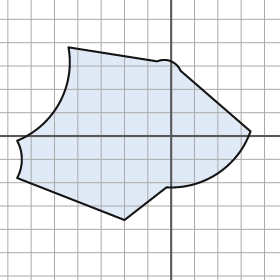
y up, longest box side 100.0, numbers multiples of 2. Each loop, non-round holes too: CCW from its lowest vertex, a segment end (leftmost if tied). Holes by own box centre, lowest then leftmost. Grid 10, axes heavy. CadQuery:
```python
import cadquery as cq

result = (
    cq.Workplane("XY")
    .moveTo(-20.0, -36.0)
    .lineTo(-2.0, -22.0)
    .threePointArc((20.0, -16.0), (34.0, 2.0))
    .lineTo(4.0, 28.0)
    .threePointArc((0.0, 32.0), (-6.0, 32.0))
    .lineTo(-44.0, 38.0)
    .threePointArc((-48.0, 14.0), (-66.0, -2.0))
    .threePointArc((-64.0, -10.0), (-66.0, -18.0))
    .close()
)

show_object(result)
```